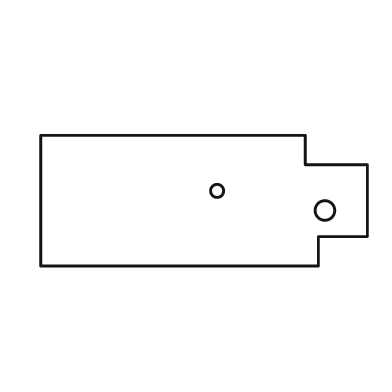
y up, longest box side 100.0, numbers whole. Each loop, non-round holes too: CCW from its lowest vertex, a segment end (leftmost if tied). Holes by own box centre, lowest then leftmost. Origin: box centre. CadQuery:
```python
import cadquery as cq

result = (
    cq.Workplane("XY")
    .moveTo(-50.0, -20.0)
    .lineTo(35.0, -20.0)
    .lineTo(35.0, -11.0)
    .lineTo(50.0, -11.0)
    .lineTo(50.0, 11.0)
    .lineTo(31.0, 11.0)
    .lineTo(31.0, 20.0)
    .lineTo(-50.0, 20.0)
    .close()
    .moveTo(37.0, -3.0)
    .circle(3.0)
    .moveTo(4.0, 3.0)
    .circle(2.0)
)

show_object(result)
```